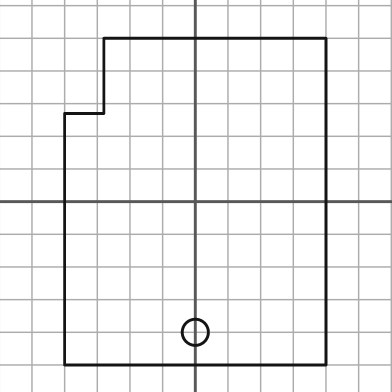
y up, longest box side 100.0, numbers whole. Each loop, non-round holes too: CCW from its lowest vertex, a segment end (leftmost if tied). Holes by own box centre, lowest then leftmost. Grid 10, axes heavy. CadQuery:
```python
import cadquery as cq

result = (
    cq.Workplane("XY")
    .moveTo(-40.0, -50.0)
    .lineTo(40.0, -50.0)
    .lineTo(40.0, 50.0)
    .lineTo(-28.0, 50.0)
    .lineTo(-28.0, 27.0)
    .lineTo(-40.0, 27.0)
    .close()
    .moveTo(0.0, -40.0)
    .circle(4.0)
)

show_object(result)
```